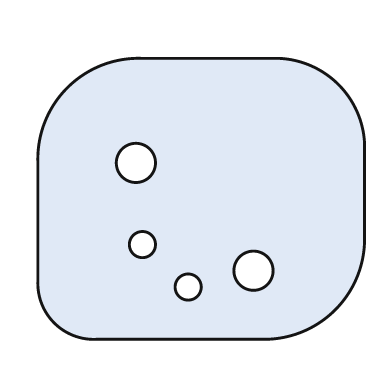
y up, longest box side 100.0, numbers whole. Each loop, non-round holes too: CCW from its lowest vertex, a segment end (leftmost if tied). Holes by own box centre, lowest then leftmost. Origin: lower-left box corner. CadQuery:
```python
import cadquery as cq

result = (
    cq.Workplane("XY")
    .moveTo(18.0, 0.0)
    .lineTo(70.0, 0.0)
    .threePointArc((91.0, 9.0), (100.0, 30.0))
    .lineTo(100.0, 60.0)
    .threePointArc((92.0, 78.0), (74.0, 86.0))
    .lineTo(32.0, 86.0)
    .threePointArc((9.0, 77.0), (0.0, 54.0))
    .lineTo(0.0, 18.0)
    .threePointArc((5.0, 5.0), (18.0, 0.0))
    .close()
    .moveTo(46.0, 16.0)
    .circle(4.0)
    .moveTo(66.0, 21.0)
    .circle(6.0)
    .moveTo(32.0, 29.0)
    .circle(4.0)
    .moveTo(30.0, 54.0)
    .circle(6.0)
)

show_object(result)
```